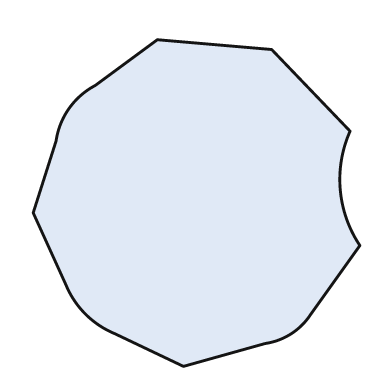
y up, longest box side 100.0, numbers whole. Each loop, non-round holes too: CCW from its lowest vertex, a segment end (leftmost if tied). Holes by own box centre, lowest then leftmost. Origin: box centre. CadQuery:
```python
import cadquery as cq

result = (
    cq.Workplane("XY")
    .moveTo(-4.0, -50.0)
    .lineTo(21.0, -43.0)
    .threePointArc((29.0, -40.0), (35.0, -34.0))
    .lineTo(50.0, -13.0)
    .threePointArc((44.0, 4.0), (47.0, 22.0))
    .lineTo(23.0, 47.0)
    .lineTo(-12.0, 50.0)
    .lineTo(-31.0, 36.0)
    .threePointArc((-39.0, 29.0), (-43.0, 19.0))
    .lineTo(-50.0, -3.0)
    .lineTo(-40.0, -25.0)
    .threePointArc((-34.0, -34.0), (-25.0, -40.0))
    .close()
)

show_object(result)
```